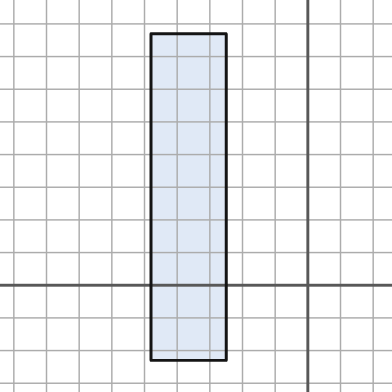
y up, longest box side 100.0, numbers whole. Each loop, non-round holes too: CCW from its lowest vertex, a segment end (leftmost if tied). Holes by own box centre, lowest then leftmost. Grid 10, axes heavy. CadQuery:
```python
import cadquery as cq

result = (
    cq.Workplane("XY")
    .moveTo(-48.0, -23.0)
    .lineTo(-25.0, -23.0)
    .lineTo(-25.0, 77.0)
    .lineTo(-48.0, 77.0)
    .close()
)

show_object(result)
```